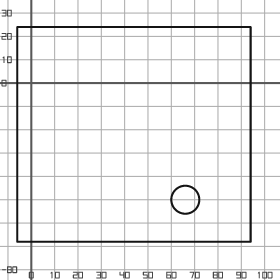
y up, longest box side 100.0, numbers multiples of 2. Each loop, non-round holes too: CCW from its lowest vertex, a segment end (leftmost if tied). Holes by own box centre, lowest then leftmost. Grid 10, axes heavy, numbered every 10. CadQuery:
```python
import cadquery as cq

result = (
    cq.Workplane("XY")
    .moveTo(-6.0, -68.0)
    .lineTo(94.0, -68.0)
    .lineTo(94.0, 24.0)
    .lineTo(-6.0, 24.0)
    .close()
    .moveTo(66.0, -50.0)
    .circle(6.0)
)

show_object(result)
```